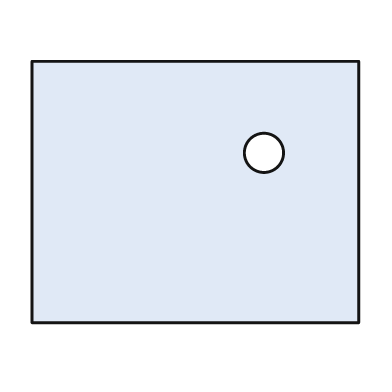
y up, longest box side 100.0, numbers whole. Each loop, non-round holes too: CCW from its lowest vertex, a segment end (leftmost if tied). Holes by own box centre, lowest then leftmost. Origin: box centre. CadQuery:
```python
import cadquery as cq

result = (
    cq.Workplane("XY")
    .moveTo(-50.0, -40.0)
    .lineTo(50.0, -40.0)
    .lineTo(50.0, 40.0)
    .lineTo(-50.0, 40.0)
    .close()
    .moveTo(21.0, 12.0)
    .circle(6.0)
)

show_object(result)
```